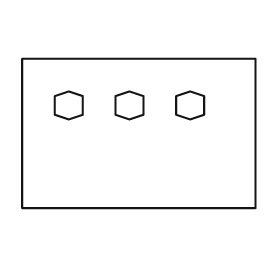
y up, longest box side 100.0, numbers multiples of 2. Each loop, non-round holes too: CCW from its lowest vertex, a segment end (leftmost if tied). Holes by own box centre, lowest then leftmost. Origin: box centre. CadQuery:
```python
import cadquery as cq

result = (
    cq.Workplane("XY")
    .moveTo(-50.0, -32.0)
    .lineTo(50.0, -32.0)
    .lineTo(50.0, 32.0)
    .lineTo(-50.0, 32.0)
    .close()
    .moveTo(-30.0, 6.0)
    .lineTo(-24.0, 8.0)
    .lineTo(-24.0, 16.0)
    .lineTo(-30.0, 18.0)
    .lineTo(-36.0, 16.0)
    .lineTo(-36.0, 8.0)
    .close()
    .moveTo(-4.0, 6.0)
    .lineTo(2.0, 8.0)
    .lineTo(2.0, 16.0)
    .lineTo(-4.0, 18.0)
    .lineTo(-10.0, 16.0)
    .lineTo(-10.0, 8.0)
    .close()
    .moveTo(22.0, 6.0)
    .lineTo(28.0, 8.0)
    .lineTo(28.0, 16.0)
    .lineTo(22.0, 18.0)
    .lineTo(16.0, 16.0)
    .lineTo(16.0, 8.0)
    .close()
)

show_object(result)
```